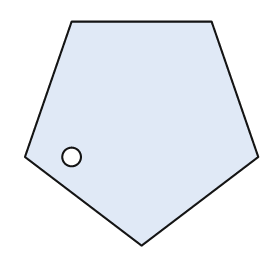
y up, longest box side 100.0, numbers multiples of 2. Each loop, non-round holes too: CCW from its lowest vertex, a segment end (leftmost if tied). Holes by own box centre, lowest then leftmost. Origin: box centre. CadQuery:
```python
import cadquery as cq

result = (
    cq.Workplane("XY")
    .moveTo(0.0, -48.0)
    .lineTo(50.0, -10.0)
    .lineTo(30.0, 48.0)
    .lineTo(-30.0, 48.0)
    .lineTo(-50.0, -10.0)
    .close()
    .moveTo(-30.0, -10.0)
    .circle(4.0)
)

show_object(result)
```